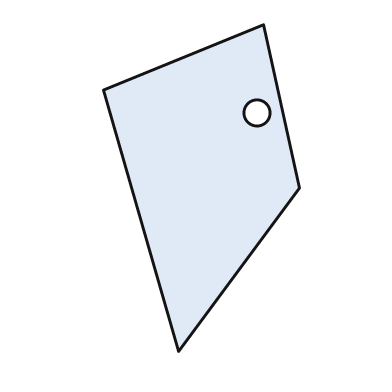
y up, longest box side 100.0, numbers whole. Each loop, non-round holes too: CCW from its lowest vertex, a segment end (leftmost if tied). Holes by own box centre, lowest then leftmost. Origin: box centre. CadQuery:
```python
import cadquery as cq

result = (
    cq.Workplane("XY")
    .moveTo(-7.0, -50.0)
    .lineTo(30.0, 0.0)
    .lineTo(19.0, 50.0)
    .lineTo(-30.0, 30.0)
    .close()
    .moveTo(17.0, 23.0)
    .circle(4.0)
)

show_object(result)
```